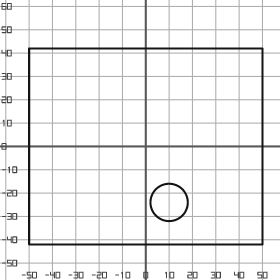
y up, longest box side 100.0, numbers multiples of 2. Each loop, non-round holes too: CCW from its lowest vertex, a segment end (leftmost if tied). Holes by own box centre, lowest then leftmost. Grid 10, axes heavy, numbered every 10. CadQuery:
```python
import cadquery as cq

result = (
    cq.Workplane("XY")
    .moveTo(-50.0, -42.0)
    .lineTo(50.0, -42.0)
    .lineTo(50.0, 42.0)
    .lineTo(-50.0, 42.0)
    .close()
    .moveTo(10.0, -24.0)
    .circle(8.0)
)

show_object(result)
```